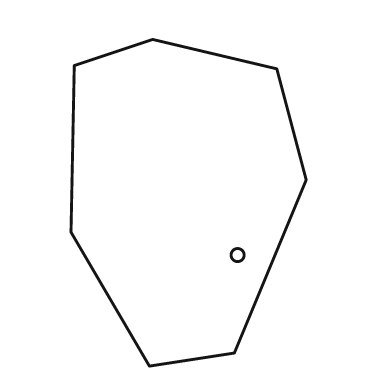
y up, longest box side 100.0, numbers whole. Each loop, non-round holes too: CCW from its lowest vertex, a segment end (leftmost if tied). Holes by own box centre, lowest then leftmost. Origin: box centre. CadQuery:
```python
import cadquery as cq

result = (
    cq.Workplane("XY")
    .moveTo(-12.0, -50.0)
    .lineTo(14.0, -46.0)
    .lineTo(36.0, 7.0)
    .lineTo(27.0, 41.0)
    .lineTo(-11.0, 50.0)
    .lineTo(-35.0, 42.0)
    .lineTo(-36.0, -9.0)
    .close()
    .moveTo(15.0, -16.0)
    .circle(2.0)
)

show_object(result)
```